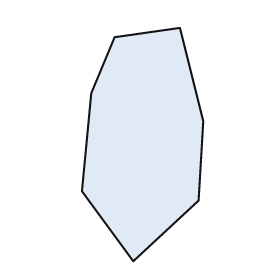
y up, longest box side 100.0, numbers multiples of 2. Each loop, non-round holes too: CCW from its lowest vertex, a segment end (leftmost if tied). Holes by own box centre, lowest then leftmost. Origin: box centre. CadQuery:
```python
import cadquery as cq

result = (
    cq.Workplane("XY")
    .moveTo(-4.0, -50.0)
    .lineTo(24.0, -24.0)
    .lineTo(26.0, 10.0)
    .lineTo(16.0, 50.0)
    .lineTo(-12.0, 46.0)
    .lineTo(-22.0, 22.0)
    .lineTo(-26.0, -20.0)
    .close()
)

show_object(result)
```